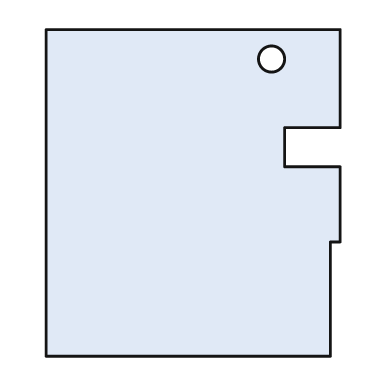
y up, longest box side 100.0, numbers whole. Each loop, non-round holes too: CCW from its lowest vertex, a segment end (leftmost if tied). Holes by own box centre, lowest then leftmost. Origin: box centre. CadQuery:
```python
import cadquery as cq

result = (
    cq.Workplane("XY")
    .moveTo(-45.0, -50.0)
    .lineTo(42.0, -50.0)
    .lineTo(42.0, -15.0)
    .lineTo(45.0, -15.0)
    .lineTo(45.0, 8.0)
    .lineTo(28.0, 8.0)
    .lineTo(28.0, 20.0)
    .lineTo(45.0, 20.0)
    .lineTo(45.0, 50.0)
    .lineTo(-45.0, 50.0)
    .close()
    .moveTo(24.0, 41.0)
    .circle(4.0)
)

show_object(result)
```